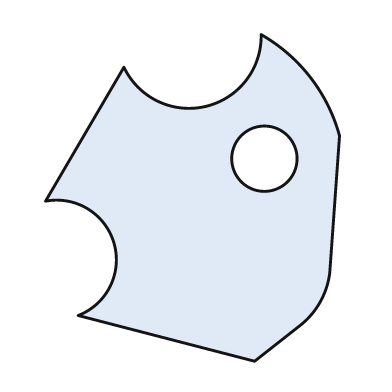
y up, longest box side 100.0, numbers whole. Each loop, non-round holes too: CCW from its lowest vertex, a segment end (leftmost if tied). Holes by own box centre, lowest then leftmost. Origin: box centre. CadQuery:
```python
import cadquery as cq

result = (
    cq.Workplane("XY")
    .moveTo(19.0, -50.0)
    .lineTo(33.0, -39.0)
    .threePointArc((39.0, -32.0), (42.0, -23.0))
    .lineTo(45.0, 19.0)
    .threePointArc((36.0, 37.0), (21.0, 50.0))
    .threePointArc((4.0, 28.0), (-21.0, 40.0))
    .lineTo(-45.0, -1.0)
    .threePointArc((-24.0, -14.0), (-35.0, -36.0))
    .close()
    .moveTo(22.0, 12.0)
    .circle(10.0)
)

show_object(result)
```